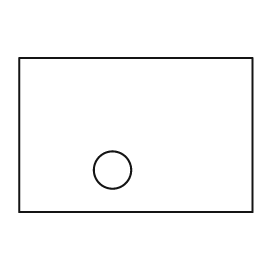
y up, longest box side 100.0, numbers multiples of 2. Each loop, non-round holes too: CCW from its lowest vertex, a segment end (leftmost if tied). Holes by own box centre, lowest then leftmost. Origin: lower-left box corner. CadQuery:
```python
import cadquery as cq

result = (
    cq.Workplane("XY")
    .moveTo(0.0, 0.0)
    .lineTo(100.0, 0.0)
    .lineTo(100.0, 66.0)
    .lineTo(0.0, 66.0)
    .close()
    .moveTo(40.0, 18.0)
    .circle(8.0)
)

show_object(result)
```